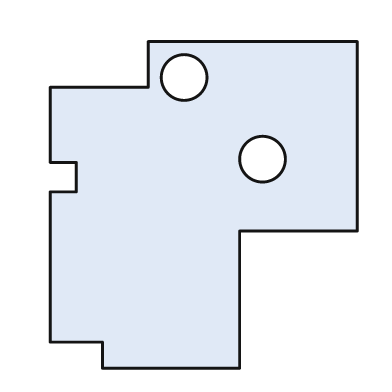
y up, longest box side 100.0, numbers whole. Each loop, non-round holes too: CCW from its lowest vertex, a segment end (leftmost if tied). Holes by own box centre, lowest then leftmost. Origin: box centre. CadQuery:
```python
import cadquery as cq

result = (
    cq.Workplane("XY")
    .moveTo(-31.0, -50.0)
    .lineTo(11.0, -50.0)
    .lineTo(11.0, -8.0)
    .lineTo(47.0, -8.0)
    .lineTo(47.0, 50.0)
    .lineTo(-17.0, 50.0)
    .lineTo(-17.0, 36.0)
    .lineTo(-47.0, 36.0)
    .lineTo(-47.0, 13.0)
    .lineTo(-39.0, 13.0)
    .lineTo(-39.0, 4.0)
    .lineTo(-47.0, 4.0)
    .lineTo(-47.0, -42.0)
    .lineTo(-31.0, -42.0)
    .close()
    .moveTo(18.0, 14.0)
    .circle(7.0)
    .moveTo(-6.0, 39.0)
    .circle(7.0)
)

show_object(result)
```